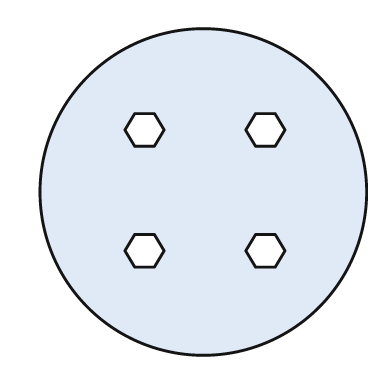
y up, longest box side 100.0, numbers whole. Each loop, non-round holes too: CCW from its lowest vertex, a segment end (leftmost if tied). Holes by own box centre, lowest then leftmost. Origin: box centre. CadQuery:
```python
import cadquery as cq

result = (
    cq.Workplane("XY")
    .moveTo(0.0, 0.0)
    .circle(50.0)
    .moveTo(-21.0, -23.0)
    .lineTo(-15.0, -23.0)
    .lineTo(-12.0, -18.0)
    .lineTo(-15.0, -13.0)
    .lineTo(-21.0, -13.0)
    .lineTo(-24.0, -18.0)
    .close()
    .moveTo(16.0, -23.0)
    .lineTo(22.0, -23.0)
    .lineTo(25.0, -18.0)
    .lineTo(22.0, -13.0)
    .lineTo(16.0, -13.0)
    .lineTo(13.0, -18.0)
    .close()
    .moveTo(-21.0, 14.0)
    .lineTo(-15.0, 14.0)
    .lineTo(-12.0, 19.0)
    .lineTo(-15.0, 24.0)
    .lineTo(-21.0, 24.0)
    .lineTo(-24.0, 19.0)
    .close()
    .moveTo(16.0, 14.0)
    .lineTo(22.0, 14.0)
    .lineTo(25.0, 19.0)
    .lineTo(22.0, 24.0)
    .lineTo(16.0, 24.0)
    .lineTo(13.0, 19.0)
    .close()
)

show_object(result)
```